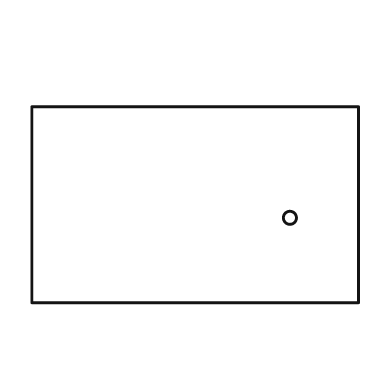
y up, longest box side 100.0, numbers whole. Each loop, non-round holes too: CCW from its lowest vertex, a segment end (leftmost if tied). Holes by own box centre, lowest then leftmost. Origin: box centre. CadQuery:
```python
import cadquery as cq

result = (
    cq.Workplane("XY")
    .moveTo(-50.0, -30.0)
    .lineTo(50.0, -30.0)
    .lineTo(50.0, 30.0)
    .lineTo(-50.0, 30.0)
    .close()
    .moveTo(29.0, -4.0)
    .circle(2.0)
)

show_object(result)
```